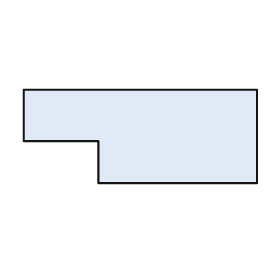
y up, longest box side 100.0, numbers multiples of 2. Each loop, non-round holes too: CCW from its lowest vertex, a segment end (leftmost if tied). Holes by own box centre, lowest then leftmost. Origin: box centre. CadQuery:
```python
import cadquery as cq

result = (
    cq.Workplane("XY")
    .moveTo(-18.0, -20.0)
    .lineTo(50.0, -20.0)
    .lineTo(50.0, 20.0)
    .lineTo(-50.0, 20.0)
    .lineTo(-50.0, -2.0)
    .lineTo(-18.0, -2.0)
    .close()
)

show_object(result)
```